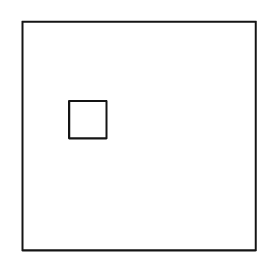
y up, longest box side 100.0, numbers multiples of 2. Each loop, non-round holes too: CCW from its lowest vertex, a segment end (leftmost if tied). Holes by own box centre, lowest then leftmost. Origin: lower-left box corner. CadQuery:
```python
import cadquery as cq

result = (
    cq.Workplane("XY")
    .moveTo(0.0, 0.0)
    .lineTo(100.0, 0.0)
    .lineTo(100.0, 98.0)
    .lineTo(0.0, 98.0)
    .close()
    .moveTo(20.0, 48.0)
    .lineTo(36.0, 48.0)
    .lineTo(36.0, 64.0)
    .lineTo(20.0, 64.0)
    .close()
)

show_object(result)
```